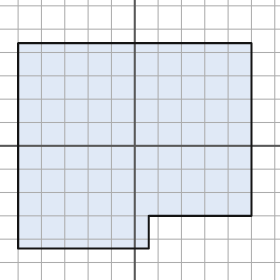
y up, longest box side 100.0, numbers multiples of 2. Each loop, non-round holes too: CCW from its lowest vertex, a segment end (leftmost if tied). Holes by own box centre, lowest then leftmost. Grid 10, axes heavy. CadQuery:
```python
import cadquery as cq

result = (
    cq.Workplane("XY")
    .moveTo(-50.0, -44.0)
    .lineTo(6.0, -44.0)
    .lineTo(6.0, -30.0)
    .lineTo(50.0, -30.0)
    .lineTo(50.0, 44.0)
    .lineTo(-50.0, 44.0)
    .close()
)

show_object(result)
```